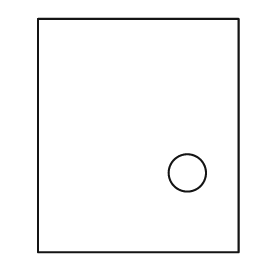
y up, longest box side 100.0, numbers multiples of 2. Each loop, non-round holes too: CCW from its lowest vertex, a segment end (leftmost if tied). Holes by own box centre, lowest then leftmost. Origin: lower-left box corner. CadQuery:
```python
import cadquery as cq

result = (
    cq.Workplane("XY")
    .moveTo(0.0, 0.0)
    .lineTo(86.0, 0.0)
    .lineTo(86.0, 100.0)
    .lineTo(0.0, 100.0)
    .close()
    .moveTo(64.0, 34.0)
    .circle(8.0)
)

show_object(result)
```